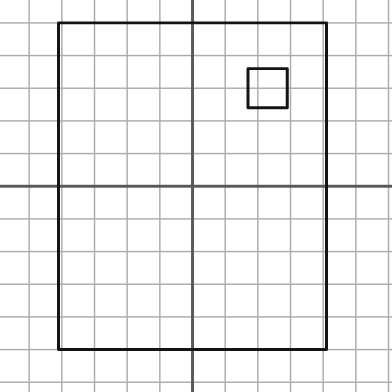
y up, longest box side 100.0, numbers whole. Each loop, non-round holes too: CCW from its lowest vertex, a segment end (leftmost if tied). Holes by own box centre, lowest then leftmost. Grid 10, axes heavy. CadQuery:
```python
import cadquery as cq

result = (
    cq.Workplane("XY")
    .moveTo(-41.0, -50.0)
    .lineTo(41.0, -50.0)
    .lineTo(41.0, 50.0)
    .lineTo(-41.0, 50.0)
    .close()
    .moveTo(17.0, 24.0)
    .lineTo(29.0, 24.0)
    .lineTo(29.0, 36.0)
    .lineTo(17.0, 36.0)
    .close()
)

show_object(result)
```